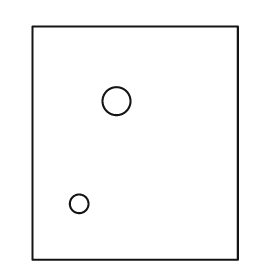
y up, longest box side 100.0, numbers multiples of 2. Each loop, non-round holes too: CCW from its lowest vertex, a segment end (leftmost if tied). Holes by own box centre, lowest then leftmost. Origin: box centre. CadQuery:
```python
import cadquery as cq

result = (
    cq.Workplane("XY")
    .moveTo(-44.0, -50.0)
    .lineTo(44.0, -50.0)
    .lineTo(44.0, 50.0)
    .lineTo(-44.0, 50.0)
    .close()
    .moveTo(-24.0, -26.0)
    .circle(4.0)
    .moveTo(-8.0, 18.0)
    .circle(6.0)
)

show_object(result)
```